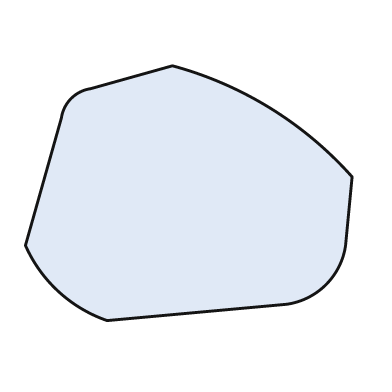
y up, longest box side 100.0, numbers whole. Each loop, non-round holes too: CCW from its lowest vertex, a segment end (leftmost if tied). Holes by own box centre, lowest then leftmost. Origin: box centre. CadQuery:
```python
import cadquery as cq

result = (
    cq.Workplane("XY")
    .moveTo(-25.0, -39.0)
    .lineTo(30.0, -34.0)
    .threePointArc((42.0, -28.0), (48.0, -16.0))
    .lineTo(50.0, 5.0)
    .threePointArc((25.0, 26.0), (-5.0, 39.0))
    .lineTo(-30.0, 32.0)
    .threePointArc((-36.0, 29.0), (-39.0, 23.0))
    .lineTo(-50.0, -16.0)
    .threePointArc((-40.0, -30.0), (-25.0, -39.0))
    .close()
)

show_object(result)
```